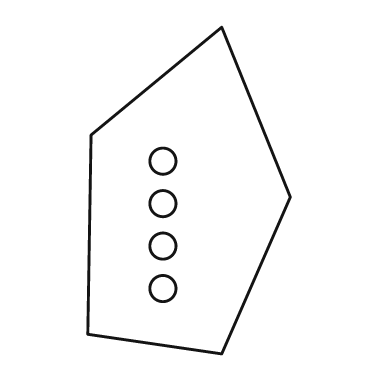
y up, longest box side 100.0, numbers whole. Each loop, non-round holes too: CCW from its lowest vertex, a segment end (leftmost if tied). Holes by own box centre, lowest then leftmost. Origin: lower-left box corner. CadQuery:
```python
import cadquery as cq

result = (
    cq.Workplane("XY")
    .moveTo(41.0, 0.0)
    .lineTo(62.0, 48.0)
    .lineTo(41.0, 100.0)
    .lineTo(1.0, 67.0)
    .lineTo(0.0, 6.0)
    .close()
    .moveTo(23.0, 20.0)
    .circle(4.0)
    .moveTo(23.0, 33.0)
    .circle(4.0)
    .moveTo(23.0, 46.0)
    .circle(4.0)
    .moveTo(23.0, 59.0)
    .circle(4.0)
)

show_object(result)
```